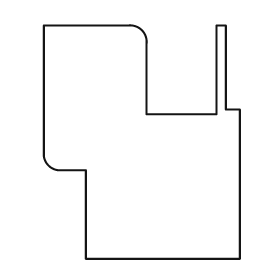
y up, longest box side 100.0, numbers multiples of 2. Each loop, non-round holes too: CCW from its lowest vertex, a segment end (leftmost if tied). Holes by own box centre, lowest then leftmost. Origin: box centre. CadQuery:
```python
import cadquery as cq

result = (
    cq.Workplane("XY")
    .moveTo(-24.0, -50.0)
    .lineTo(42.0, -50.0)
    .lineTo(42.0, 14.0)
    .lineTo(36.0, 14.0)
    .lineTo(36.0, 50.0)
    .lineTo(32.0, 50.0)
    .lineTo(32.0, 12.0)
    .lineTo(2.0, 12.0)
    .lineTo(2.0, 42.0)
    .threePointArc((0.0, 48.0), (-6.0, 50.0))
    .lineTo(-42.0, 50.0)
    .lineTo(-42.0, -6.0)
    .threePointArc((-40.0, -10.0), (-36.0, -12.0))
    .lineTo(-24.0, -12.0)
    .close()
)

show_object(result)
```